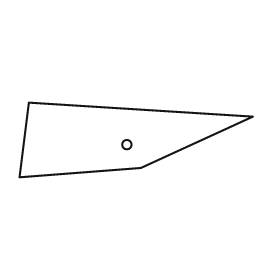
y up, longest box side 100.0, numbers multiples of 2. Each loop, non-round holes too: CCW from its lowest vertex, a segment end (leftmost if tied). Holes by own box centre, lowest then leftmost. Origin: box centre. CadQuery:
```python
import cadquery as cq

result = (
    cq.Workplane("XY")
    .moveTo(-50.0, -16.0)
    .lineTo(2.0, -12.0)
    .lineTo(50.0, 10.0)
    .lineTo(-46.0, 16.0)
    .close()
    .moveTo(-4.0, -2.0)
    .circle(2.0)
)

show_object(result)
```